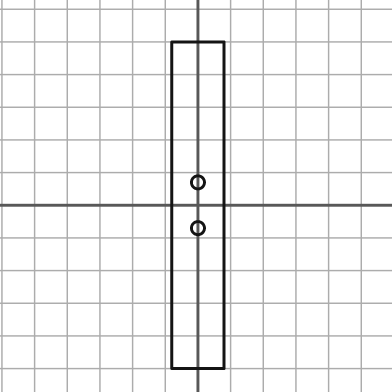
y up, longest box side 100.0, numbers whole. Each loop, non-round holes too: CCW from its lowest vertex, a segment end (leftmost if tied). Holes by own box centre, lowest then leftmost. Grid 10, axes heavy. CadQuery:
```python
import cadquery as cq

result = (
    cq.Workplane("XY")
    .moveTo(-8.0, -50.0)
    .lineTo(8.0, -50.0)
    .lineTo(8.0, 50.0)
    .lineTo(-8.0, 50.0)
    .close()
    .moveTo(0.0, -7.0)
    .circle(2.0)
    .moveTo(0.0, 7.0)
    .circle(2.0)
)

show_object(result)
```